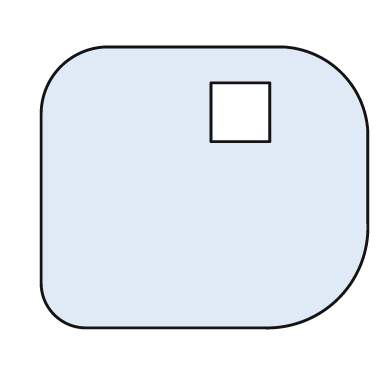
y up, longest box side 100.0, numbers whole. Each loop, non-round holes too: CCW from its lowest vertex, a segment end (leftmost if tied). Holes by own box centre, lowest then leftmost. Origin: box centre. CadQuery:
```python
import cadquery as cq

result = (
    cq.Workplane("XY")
    .moveTo(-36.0, -43.0)
    .lineTo(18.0, -43.0)
    .threePointArc((41.0, -34.0), (50.0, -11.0))
    .lineTo(50.0, 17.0)
    .threePointArc((42.0, 35.0), (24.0, 43.0))
    .lineTo(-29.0, 43.0)
    .threePointArc((-44.0, 37.0), (-50.0, 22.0))
    .lineTo(-50.0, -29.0)
    .threePointArc((-46.0, -39.0), (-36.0, -43.0))
    .close()
    .moveTo(2.0, 14.0)
    .lineTo(20.0, 14.0)
    .lineTo(20.0, 32.0)
    .lineTo(2.0, 32.0)
    .close()
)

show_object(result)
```